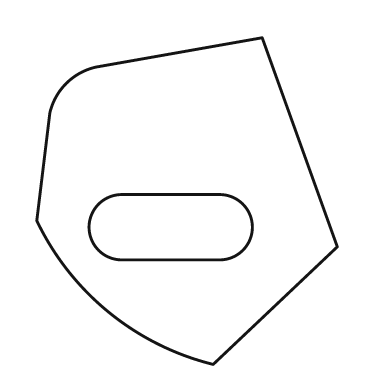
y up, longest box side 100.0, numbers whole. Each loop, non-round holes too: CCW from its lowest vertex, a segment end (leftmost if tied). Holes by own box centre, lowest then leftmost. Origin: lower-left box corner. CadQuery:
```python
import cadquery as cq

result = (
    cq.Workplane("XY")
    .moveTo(54.0, 0.0)
    .lineTo(92.0, 36.0)
    .lineTo(69.0, 100.0)
    .lineTo(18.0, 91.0)
    .threePointArc((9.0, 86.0), (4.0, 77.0))
    .lineTo(0.0, 44.0)
    .threePointArc((22.0, 16.0), (54.0, 0.0))
    .close()
    .moveTo(26.0, 32.0)
    .lineTo(56.0, 32.0)
    .threePointArc((66.0, 42.0), (56.0, 52.0))
    .lineTo(26.0, 52.0)
    .threePointArc((16.0, 42.0), (26.0, 32.0))
    .close()
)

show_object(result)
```